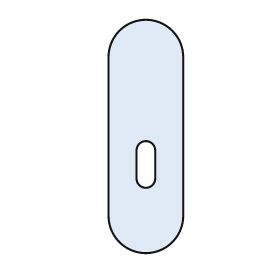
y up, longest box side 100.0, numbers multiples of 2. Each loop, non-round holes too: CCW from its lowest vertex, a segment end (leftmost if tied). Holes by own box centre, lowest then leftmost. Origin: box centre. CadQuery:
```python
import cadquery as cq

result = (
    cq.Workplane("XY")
    .moveTo(-16.0, -34.0)
    .threePointArc((0.0, -50.0), (16.0, -34.0))
    .lineTo(16.0, 34.0)
    .threePointArc((0.0, 50.0), (-16.0, 34.0))
    .close()
    .moveTo(-4.0, -18.0)
    .threePointArc((0.0, -22.0), (4.0, -18.0))
    .lineTo(4.0, -6.0)
    .threePointArc((0.0, -2.0), (-4.0, -6.0))
    .close()
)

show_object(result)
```